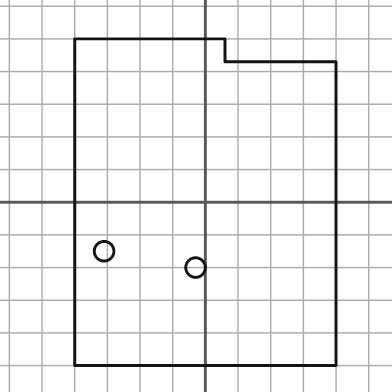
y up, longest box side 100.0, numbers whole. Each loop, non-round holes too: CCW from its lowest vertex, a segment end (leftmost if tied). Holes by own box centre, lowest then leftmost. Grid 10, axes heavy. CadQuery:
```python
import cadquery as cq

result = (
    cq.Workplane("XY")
    .moveTo(-40.0, -50.0)
    .lineTo(40.0, -50.0)
    .lineTo(40.0, 43.0)
    .lineTo(6.0, 43.0)
    .lineTo(6.0, 50.0)
    .lineTo(-40.0, 50.0)
    .close()
    .moveTo(-3.0, -20.0)
    .circle(3.0)
    .moveTo(-31.0, -15.0)
    .circle(3.0)
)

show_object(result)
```